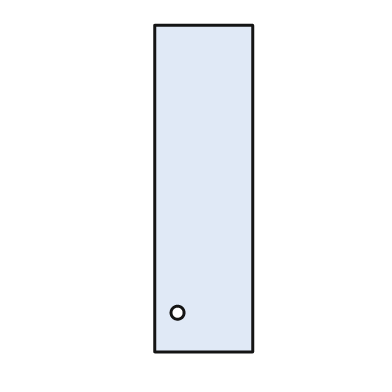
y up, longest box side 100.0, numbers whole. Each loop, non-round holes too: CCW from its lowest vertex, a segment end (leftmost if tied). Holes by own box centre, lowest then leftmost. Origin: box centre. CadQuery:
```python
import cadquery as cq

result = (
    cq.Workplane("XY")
    .moveTo(-15.0, -50.0)
    .lineTo(15.0, -50.0)
    .lineTo(15.0, 50.0)
    .lineTo(-15.0, 50.0)
    .close()
    .moveTo(-8.0, -38.0)
    .circle(2.0)
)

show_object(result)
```